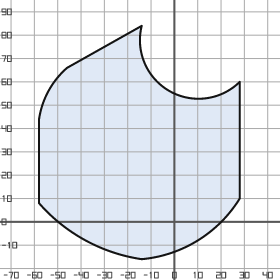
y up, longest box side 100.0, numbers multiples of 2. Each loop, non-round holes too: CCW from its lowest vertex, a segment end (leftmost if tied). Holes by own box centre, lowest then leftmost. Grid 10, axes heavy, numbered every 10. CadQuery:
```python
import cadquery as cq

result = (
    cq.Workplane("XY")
    .moveTo(-14.0, -16.0)
    .threePointArc((10.0, -8.0), (28.0, 10.0))
    .lineTo(28.0, 60.0)
    .threePointArc((-2.0, 56.0), (-14.0, 84.0))
    .lineTo(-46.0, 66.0)
    .threePointArc((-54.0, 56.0), (-58.0, 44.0))
    .lineTo(-58.0, 8.0)
    .threePointArc((-38.0, -8.0), (-14.0, -16.0))
    .close()
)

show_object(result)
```